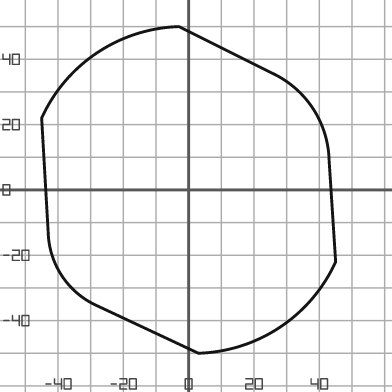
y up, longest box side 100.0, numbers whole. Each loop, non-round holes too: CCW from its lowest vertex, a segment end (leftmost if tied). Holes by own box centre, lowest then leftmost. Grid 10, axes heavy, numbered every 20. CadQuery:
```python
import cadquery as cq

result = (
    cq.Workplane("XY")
    .moveTo(3.0, -50.0)
    .threePointArc((28.0, -42.0), (45.0, -22.0))
    .lineTo(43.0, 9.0)
    .threePointArc((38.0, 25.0), (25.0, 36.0))
    .lineTo(-3.0, 50.0)
    .threePointArc((-28.0, 42.0), (-45.0, 22.0))
    .lineTo(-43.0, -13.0)
    .threePointArc((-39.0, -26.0), (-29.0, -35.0))
    .close()
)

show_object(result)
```